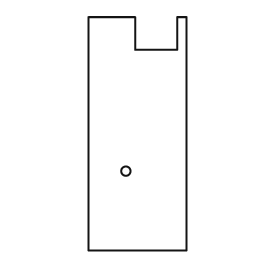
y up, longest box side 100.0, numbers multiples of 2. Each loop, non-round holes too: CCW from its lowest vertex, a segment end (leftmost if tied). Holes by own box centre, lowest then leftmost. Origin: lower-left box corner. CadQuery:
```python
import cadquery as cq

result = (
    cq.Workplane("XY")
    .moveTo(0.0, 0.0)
    .lineTo(42.0, 0.0)
    .lineTo(42.0, 100.0)
    .lineTo(38.0, 100.0)
    .lineTo(38.0, 86.0)
    .lineTo(20.0, 86.0)
    .lineTo(20.0, 100.0)
    .lineTo(0.0, 100.0)
    .close()
    .moveTo(16.0, 34.0)
    .circle(2.0)
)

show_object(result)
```